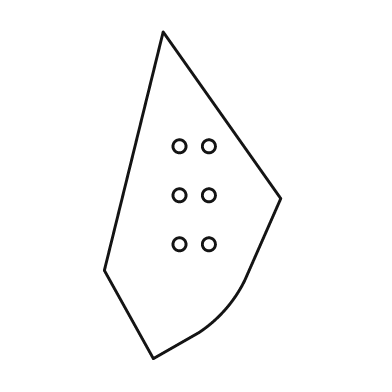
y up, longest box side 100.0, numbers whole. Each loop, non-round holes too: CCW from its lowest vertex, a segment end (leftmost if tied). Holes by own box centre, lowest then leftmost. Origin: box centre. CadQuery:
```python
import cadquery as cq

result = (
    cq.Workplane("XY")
    .moveTo(-12.0, -50.0)
    .lineTo(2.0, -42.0)
    .threePointArc((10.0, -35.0), (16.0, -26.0))
    .lineTo(27.0, -1.0)
    .lineTo(-9.0, 50.0)
    .lineTo(-27.0, -23.0)
    .close()
    .moveTo(-4.0, -15.0)
    .circle(2.0)
    .moveTo(5.0, -15.0)
    .circle(2.0)
    .moveTo(-4.0, 0.0)
    .circle(2.0)
    .moveTo(5.0, 0.0)
    .circle(2.0)
    .moveTo(-4.0, 15.0)
    .circle(2.0)
    .moveTo(5.0, 15.0)
    .circle(2.0)
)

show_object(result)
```